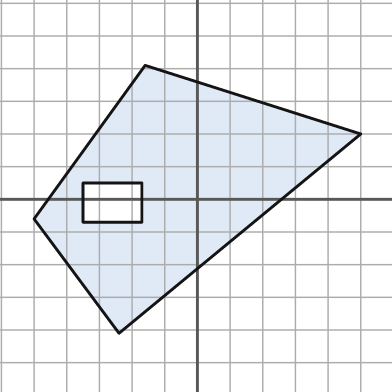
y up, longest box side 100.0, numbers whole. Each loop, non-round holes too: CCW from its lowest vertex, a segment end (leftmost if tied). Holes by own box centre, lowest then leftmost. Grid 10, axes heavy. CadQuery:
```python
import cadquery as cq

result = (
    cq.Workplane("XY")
    .moveTo(-24.0, -41.0)
    .lineTo(50.0, 20.0)
    .lineTo(-16.0, 41.0)
    .lineTo(-50.0, -6.0)
    .close()
    .moveTo(-35.0, -7.0)
    .lineTo(-17.0, -7.0)
    .lineTo(-17.0, 5.0)
    .lineTo(-35.0, 5.0)
    .close()
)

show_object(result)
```